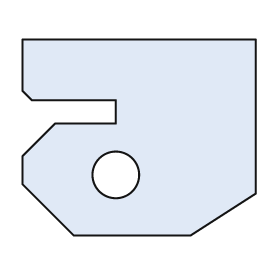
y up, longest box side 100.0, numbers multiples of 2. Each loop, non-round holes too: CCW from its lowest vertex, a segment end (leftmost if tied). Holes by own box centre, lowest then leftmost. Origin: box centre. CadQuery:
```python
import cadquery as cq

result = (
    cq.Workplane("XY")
    .moveTo(-28.0, -42.0)
    .lineTo(22.0, -42.0)
    .lineTo(50.0, -24.0)
    .lineTo(50.0, 42.0)
    .lineTo(-50.0, 42.0)
    .lineTo(-50.0, 20.0)
    .lineTo(-46.0, 16.0)
    .lineTo(-10.0, 16.0)
    .lineTo(-10.0, 6.0)
    .lineTo(-36.0, 6.0)
    .lineTo(-50.0, -8.0)
    .lineTo(-50.0, -20.0)
    .close()
    .moveTo(-10.0, -16.0)
    .circle(10.0)
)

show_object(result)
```